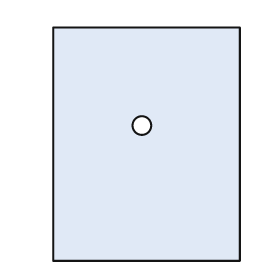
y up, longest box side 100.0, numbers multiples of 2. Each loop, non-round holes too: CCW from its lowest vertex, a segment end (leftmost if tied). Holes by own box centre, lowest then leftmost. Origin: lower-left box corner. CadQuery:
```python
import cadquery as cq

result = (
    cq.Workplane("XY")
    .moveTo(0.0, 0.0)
    .lineTo(80.0, 0.0)
    .lineTo(80.0, 100.0)
    .lineTo(0.0, 100.0)
    .close()
    .moveTo(38.0, 58.0)
    .circle(4.0)
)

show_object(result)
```